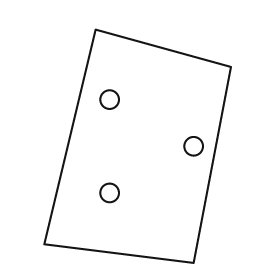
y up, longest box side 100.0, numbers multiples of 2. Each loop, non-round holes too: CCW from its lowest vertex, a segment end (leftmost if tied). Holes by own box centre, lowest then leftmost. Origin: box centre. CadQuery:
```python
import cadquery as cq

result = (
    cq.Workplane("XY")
    .moveTo(24.0, -50.0)
    .lineTo(40.0, 34.0)
    .lineTo(-18.0, 50.0)
    .lineTo(-40.0, -42.0)
    .close()
    .moveTo(-12.0, -20.0)
    .circle(4.0)
    .moveTo(24.0, 0.0)
    .circle(4.0)
    .moveTo(-12.0, 20.0)
    .circle(4.0)
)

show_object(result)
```